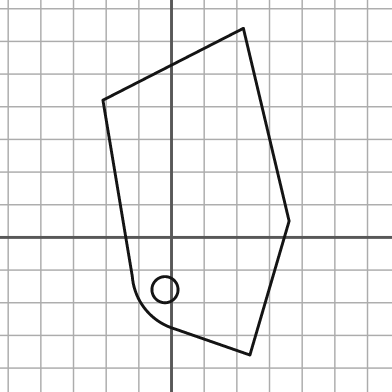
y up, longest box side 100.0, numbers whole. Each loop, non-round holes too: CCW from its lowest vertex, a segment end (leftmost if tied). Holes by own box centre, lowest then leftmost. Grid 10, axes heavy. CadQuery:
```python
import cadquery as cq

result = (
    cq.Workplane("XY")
    .moveTo(24.0, -36.0)
    .lineTo(36.0, 5.0)
    .lineTo(22.0, 64.0)
    .lineTo(-21.0, 42.0)
    .lineTo(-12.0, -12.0)
    .threePointArc((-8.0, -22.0), (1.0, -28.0))
    .close()
    .moveTo(-2.0, -16.0)
    .circle(4.0)
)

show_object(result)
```